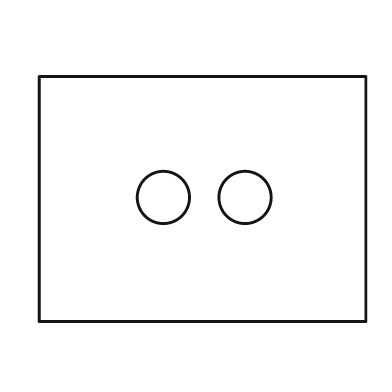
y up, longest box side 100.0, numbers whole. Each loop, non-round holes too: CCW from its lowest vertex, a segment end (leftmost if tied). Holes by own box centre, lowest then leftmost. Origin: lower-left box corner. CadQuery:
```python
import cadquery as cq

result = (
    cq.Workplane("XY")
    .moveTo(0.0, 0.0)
    .lineTo(100.0, 0.0)
    .lineTo(100.0, 75.0)
    .lineTo(0.0, 75.0)
    .close()
    .moveTo(38.0, 38.0)
    .circle(8.0)
    .moveTo(63.0, 38.0)
    .circle(8.0)
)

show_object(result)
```